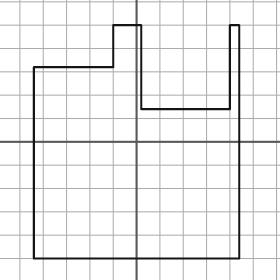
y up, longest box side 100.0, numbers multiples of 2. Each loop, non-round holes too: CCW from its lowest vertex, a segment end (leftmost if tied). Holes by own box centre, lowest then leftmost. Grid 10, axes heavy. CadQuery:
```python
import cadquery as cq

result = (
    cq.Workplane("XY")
    .moveTo(-44.0, -50.0)
    .lineTo(44.0, -50.0)
    .lineTo(44.0, 50.0)
    .lineTo(40.0, 50.0)
    .lineTo(40.0, 14.0)
    .lineTo(2.0, 14.0)
    .lineTo(2.0, 50.0)
    .lineTo(-10.0, 50.0)
    .lineTo(-10.0, 32.0)
    .lineTo(-44.0, 32.0)
    .close()
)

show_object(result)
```